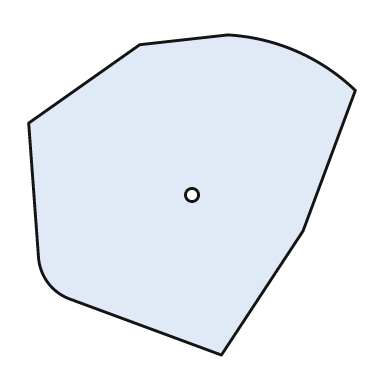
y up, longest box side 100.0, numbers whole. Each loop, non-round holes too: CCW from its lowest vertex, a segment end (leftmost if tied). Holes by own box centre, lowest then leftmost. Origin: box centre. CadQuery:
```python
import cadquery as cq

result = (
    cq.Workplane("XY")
    .moveTo(9.0, -49.0)
    .lineTo(34.0, -11.0)
    .lineTo(50.0, 32.0)
    .threePointArc((32.0, 44.0), (11.0, 49.0))
    .lineTo(-16.0, 46.0)
    .lineTo(-50.0, 22.0)
    .lineTo(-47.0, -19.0)
    .threePointArc((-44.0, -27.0), (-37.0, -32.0))
    .close()
    .moveTo(0.0, 0.0)
    .circle(2.0)
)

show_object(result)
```